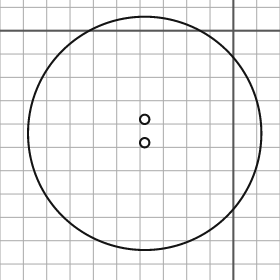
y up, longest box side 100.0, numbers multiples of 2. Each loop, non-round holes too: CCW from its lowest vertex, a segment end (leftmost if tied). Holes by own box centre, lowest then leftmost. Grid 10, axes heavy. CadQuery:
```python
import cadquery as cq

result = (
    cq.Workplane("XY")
    .moveTo(-38.0, -44.0)
    .circle(50.0)
    .moveTo(-38.0, -48.0)
    .circle(2.0)
    .moveTo(-38.0, -38.0)
    .circle(2.0)
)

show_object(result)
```